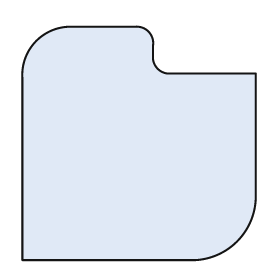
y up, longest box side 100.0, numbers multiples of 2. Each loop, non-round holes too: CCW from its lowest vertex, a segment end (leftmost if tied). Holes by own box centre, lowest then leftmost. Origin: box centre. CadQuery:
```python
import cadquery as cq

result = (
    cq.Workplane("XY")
    .moveTo(-50.0, -50.0)
    .lineTo(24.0, -50.0)
    .threePointArc((42.0, -42.0), (50.0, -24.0))
    .lineTo(50.0, 30.0)
    .lineTo(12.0, 30.0)
    .threePointArc((8.0, 32.0), (6.0, 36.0))
    .lineTo(6.0, 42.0)
    .threePointArc((4.0, 48.0), (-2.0, 50.0))
    .lineTo(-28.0, 50.0)
    .threePointArc((-44.0, 44.0), (-50.0, 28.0))
    .close()
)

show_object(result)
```